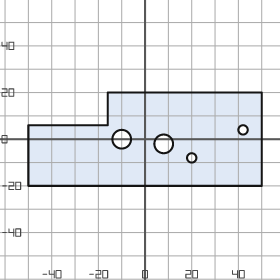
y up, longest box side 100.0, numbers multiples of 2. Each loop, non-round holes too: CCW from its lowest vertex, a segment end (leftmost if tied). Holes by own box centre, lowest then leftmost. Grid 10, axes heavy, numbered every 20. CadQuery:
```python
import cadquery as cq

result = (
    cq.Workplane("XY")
    .moveTo(-50.0, -20.0)
    .lineTo(50.0, -20.0)
    .lineTo(50.0, 20.0)
    .lineTo(-16.0, 20.0)
    .lineTo(-16.0, 6.0)
    .lineTo(-50.0, 6.0)
    .close()
    .moveTo(20.0, -8.0)
    .circle(2.0)
    .moveTo(8.0, -2.0)
    .circle(4.0)
    .moveTo(-10.0, 0.0)
    .circle(4.0)
    .moveTo(42.0, 4.0)
    .circle(2.0)
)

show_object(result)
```